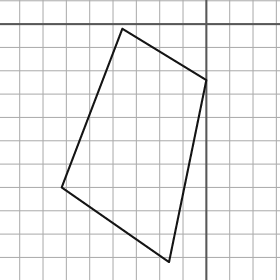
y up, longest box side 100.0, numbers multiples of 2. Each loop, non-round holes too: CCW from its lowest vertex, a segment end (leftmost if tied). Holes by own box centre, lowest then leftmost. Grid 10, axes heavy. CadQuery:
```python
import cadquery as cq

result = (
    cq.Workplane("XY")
    .moveTo(-16.0, -102.0)
    .lineTo(0.0, -24.0)
    .lineTo(-36.0, -2.0)
    .lineTo(-62.0, -70.0)
    .close()
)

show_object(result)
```